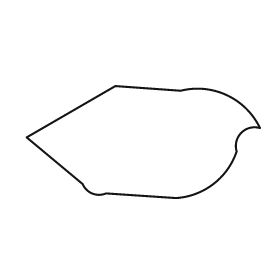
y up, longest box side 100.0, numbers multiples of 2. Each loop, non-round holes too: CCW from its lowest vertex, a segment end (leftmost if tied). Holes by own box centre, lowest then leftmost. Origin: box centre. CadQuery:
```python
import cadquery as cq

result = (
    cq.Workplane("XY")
    .moveTo(14.0, -24.0)
    .threePointArc((30.0, -18.0), (40.0, -4.0))
    .threePointArc((42.0, 4.0), (50.0, 6.0))
    .threePointArc((36.0, 20.0), (16.0, 22.0))
    .lineTo(-12.0, 24.0)
    .lineTo(-50.0, 2.0)
    .lineTo(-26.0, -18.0)
    .threePointArc((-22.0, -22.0), (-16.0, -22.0))
    .close()
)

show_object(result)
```